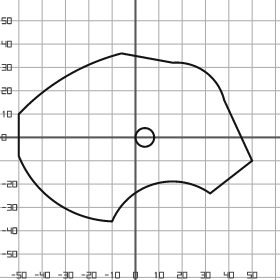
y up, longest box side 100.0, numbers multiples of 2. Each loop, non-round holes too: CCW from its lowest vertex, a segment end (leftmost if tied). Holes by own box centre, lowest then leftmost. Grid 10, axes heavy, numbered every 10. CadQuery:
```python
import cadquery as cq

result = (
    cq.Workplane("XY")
    .moveTo(-10.0, -36.0)
    .threePointArc((8.0, -20.0), (32.0, -24.0))
    .lineTo(50.0, -10.0)
    .lineTo(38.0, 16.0)
    .threePointArc((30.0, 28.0), (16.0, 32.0))
    .lineTo(-6.0, 36.0)
    .threePointArc((-30.0, 26.0), (-50.0, 10.0))
    .lineTo(-50.0, -8.0)
    .threePointArc((-34.0, -28.0), (-10.0, -36.0))
    .close()
    .moveTo(4.0, 0.0)
    .circle(4.0)
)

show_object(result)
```